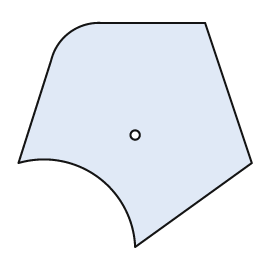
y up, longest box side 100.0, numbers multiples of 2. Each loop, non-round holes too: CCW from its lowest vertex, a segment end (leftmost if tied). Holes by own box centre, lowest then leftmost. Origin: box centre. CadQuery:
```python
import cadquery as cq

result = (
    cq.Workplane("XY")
    .moveTo(0.0, -48.0)
    .lineTo(50.0, -12.0)
    .lineTo(30.0, 48.0)
    .lineTo(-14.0, 48.0)
    .threePointArc((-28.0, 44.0), (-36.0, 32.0))
    .lineTo(-50.0, -12.0)
    .threePointArc((-16.0, -18.0), (0.0, -48.0))
    .close()
    .moveTo(0.0, 0.0)
    .circle(2.0)
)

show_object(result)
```